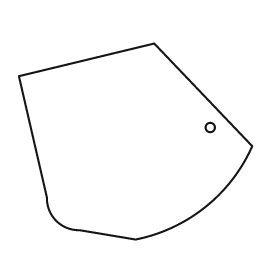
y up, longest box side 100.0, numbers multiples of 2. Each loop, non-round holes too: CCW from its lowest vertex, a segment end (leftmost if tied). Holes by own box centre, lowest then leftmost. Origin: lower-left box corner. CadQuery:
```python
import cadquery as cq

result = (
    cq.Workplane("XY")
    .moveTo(50.0, 0.0)
    .threePointArc((80.0, 14.0), (100.0, 40.0))
    .lineTo(58.0, 84.0)
    .lineTo(0.0, 70.0)
    .lineTo(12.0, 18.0)
    .threePointArc((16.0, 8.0), (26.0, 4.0))
    .close()
    .moveTo(82.0, 48.0)
    .circle(2.0)
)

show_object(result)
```